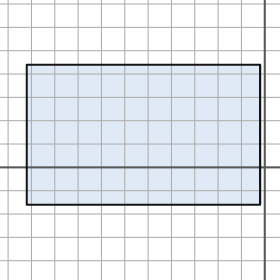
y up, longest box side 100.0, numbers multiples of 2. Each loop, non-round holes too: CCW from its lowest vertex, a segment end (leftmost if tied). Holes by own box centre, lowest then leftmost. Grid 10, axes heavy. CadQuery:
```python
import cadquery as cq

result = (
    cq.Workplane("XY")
    .moveTo(-102.0, -16.0)
    .lineTo(-2.0, -16.0)
    .lineTo(-2.0, 44.0)
    .lineTo(-102.0, 44.0)
    .close()
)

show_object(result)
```